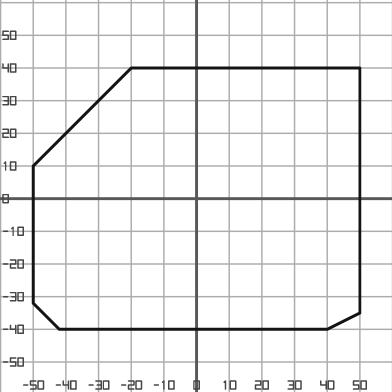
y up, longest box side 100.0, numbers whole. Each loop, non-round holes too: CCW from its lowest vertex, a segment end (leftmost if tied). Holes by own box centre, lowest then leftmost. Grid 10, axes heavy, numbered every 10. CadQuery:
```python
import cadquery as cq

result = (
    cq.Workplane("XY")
    .moveTo(-42.0, -40.0)
    .lineTo(40.0, -40.0)
    .lineTo(50.0, -35.0)
    .lineTo(50.0, 40.0)
    .lineTo(-20.0, 40.0)
    .lineTo(-50.0, 10.0)
    .lineTo(-50.0, -32.0)
    .close()
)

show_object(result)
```